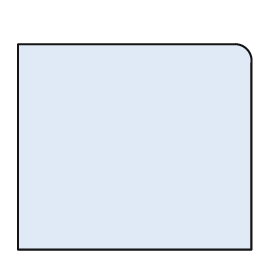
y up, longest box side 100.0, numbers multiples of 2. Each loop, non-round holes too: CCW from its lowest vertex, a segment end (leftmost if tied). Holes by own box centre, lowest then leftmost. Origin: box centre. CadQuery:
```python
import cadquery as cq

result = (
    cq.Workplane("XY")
    .moveTo(-50.0, -44.0)
    .lineTo(50.0, -44.0)
    .lineTo(50.0, 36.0)
    .threePointArc((48.0, 42.0), (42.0, 44.0))
    .lineTo(-50.0, 44.0)
    .close()
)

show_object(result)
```